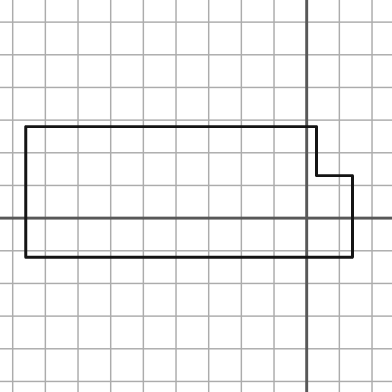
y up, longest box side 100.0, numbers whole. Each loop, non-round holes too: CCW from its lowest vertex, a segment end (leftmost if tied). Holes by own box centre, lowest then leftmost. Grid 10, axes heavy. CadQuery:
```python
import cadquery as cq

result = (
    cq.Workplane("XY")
    .moveTo(-86.0, -12.0)
    .lineTo(14.0, -12.0)
    .lineTo(14.0, 13.0)
    .lineTo(3.0, 13.0)
    .lineTo(3.0, 28.0)
    .lineTo(-86.0, 28.0)
    .close()
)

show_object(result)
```